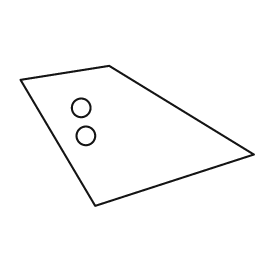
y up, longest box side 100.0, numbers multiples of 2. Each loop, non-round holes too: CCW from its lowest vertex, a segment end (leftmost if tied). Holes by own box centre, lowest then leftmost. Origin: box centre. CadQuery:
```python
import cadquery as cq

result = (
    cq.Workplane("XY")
    .moveTo(-18.0, -30.0)
    .lineTo(50.0, -8.0)
    .lineTo(-12.0, 30.0)
    .lineTo(-50.0, 24.0)
    .close()
    .moveTo(-22.0, 0.0)
    .circle(4.0)
    .moveTo(-24.0, 12.0)
    .circle(4.0)
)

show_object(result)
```